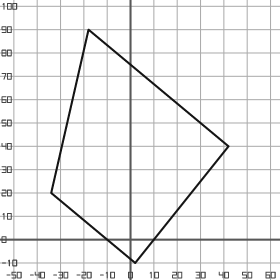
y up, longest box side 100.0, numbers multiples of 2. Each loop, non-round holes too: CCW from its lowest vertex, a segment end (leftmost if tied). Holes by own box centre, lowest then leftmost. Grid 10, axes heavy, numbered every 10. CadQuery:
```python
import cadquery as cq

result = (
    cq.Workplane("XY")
    .moveTo(2.0, -10.0)
    .lineTo(42.0, 40.0)
    .lineTo(-18.0, 90.0)
    .lineTo(-34.0, 20.0)
    .close()
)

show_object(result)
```